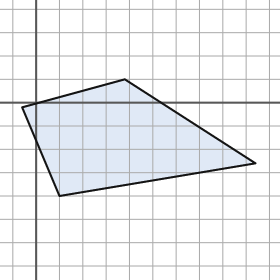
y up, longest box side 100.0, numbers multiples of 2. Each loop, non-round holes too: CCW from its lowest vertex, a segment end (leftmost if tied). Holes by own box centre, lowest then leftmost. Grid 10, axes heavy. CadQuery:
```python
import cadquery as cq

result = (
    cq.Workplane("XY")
    .moveTo(10.0, -40.0)
    .lineTo(94.0, -26.0)
    .lineTo(38.0, 10.0)
    .lineTo(-6.0, -2.0)
    .close()
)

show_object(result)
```